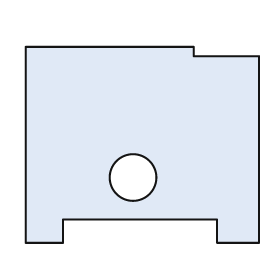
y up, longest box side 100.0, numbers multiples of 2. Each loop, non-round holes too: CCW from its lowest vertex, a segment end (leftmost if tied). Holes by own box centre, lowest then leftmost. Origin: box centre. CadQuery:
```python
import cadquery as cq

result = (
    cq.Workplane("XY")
    .moveTo(-50.0, -42.0)
    .lineTo(-34.0, -42.0)
    .lineTo(-34.0, -32.0)
    .lineTo(32.0, -32.0)
    .lineTo(32.0, -42.0)
    .lineTo(50.0, -42.0)
    .lineTo(50.0, 38.0)
    .lineTo(22.0, 38.0)
    .lineTo(22.0, 42.0)
    .lineTo(-50.0, 42.0)
    .close()
    .moveTo(-4.0, -14.0)
    .circle(10.0)
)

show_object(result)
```